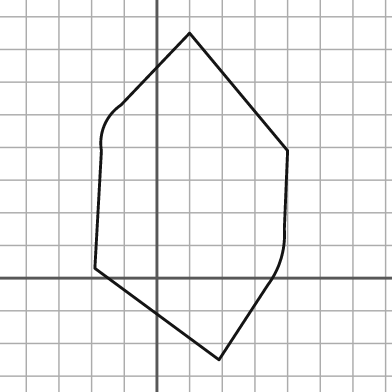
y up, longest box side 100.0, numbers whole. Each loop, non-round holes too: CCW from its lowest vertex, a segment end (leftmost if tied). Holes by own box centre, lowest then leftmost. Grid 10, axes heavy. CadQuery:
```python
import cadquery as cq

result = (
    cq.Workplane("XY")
    .moveTo(19.0, -25.0)
    .lineTo(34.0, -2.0)
    .threePointArc((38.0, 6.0), (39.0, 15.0))
    .lineTo(40.0, 39.0)
    .lineTo(10.0, 75.0)
    .lineTo(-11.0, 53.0)
    .threePointArc((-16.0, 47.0), (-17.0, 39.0))
    .lineTo(-19.0, 3.0)
    .close()
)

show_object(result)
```